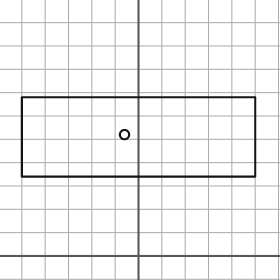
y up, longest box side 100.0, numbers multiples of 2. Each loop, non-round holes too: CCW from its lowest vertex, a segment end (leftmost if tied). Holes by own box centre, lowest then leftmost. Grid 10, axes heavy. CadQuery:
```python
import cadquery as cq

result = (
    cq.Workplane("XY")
    .moveTo(-50.0, 34.0)
    .lineTo(50.0, 34.0)
    .lineTo(50.0, 68.0)
    .lineTo(-50.0, 68.0)
    .close()
    .moveTo(-6.0, 52.0)
    .circle(2.0)
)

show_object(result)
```